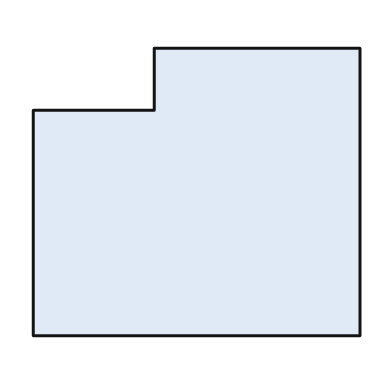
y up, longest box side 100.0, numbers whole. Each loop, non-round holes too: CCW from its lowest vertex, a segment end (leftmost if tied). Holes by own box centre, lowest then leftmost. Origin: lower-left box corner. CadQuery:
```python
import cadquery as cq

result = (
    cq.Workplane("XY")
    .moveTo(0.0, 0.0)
    .lineTo(100.0, 0.0)
    .lineTo(100.0, 88.0)
    .lineTo(37.0, 88.0)
    .lineTo(37.0, 69.0)
    .lineTo(0.0, 69.0)
    .close()
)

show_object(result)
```